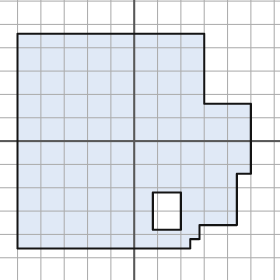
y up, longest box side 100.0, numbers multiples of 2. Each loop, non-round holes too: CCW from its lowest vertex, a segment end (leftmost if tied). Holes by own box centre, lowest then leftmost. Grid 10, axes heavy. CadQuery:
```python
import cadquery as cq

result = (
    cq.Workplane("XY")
    .moveTo(-50.0, -46.0)
    .lineTo(24.0, -46.0)
    .lineTo(24.0, -42.0)
    .lineTo(28.0, -42.0)
    .lineTo(28.0, -36.0)
    .lineTo(44.0, -36.0)
    .lineTo(44.0, -14.0)
    .lineTo(50.0, -14.0)
    .lineTo(50.0, 16.0)
    .lineTo(30.0, 16.0)
    .lineTo(30.0, 46.0)
    .lineTo(-50.0, 46.0)
    .close()
    .moveTo(8.0, -38.0)
    .lineTo(20.0, -38.0)
    .lineTo(20.0, -22.0)
    .lineTo(8.0, -22.0)
    .close()
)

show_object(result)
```